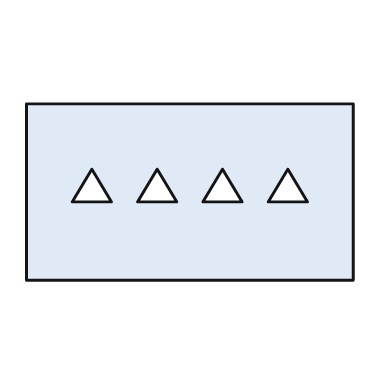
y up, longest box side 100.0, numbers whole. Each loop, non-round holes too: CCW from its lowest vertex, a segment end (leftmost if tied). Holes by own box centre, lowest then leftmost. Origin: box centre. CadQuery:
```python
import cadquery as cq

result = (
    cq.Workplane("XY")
    .moveTo(-50.0, -27.0)
    .lineTo(50.0, -27.0)
    .lineTo(50.0, 27.0)
    .lineTo(-50.0, 27.0)
    .close()
    .moveTo(-36.0, -3.0)
    .lineTo(-24.0, -3.0)
    .lineTo(-30.0, 7.0)
    .close()
    .moveTo(-16.0, -3.0)
    .lineTo(-4.0, -3.0)
    .lineTo(-10.0, 7.0)
    .close()
    .moveTo(4.0, -3.0)
    .lineTo(16.0, -3.0)
    .lineTo(10.0, 7.0)
    .close()
    .moveTo(24.0, -3.0)
    .lineTo(36.0, -3.0)
    .lineTo(30.0, 7.0)
    .close()
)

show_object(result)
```